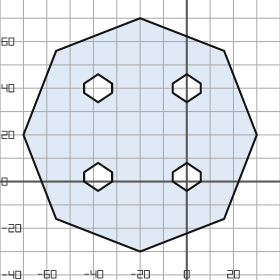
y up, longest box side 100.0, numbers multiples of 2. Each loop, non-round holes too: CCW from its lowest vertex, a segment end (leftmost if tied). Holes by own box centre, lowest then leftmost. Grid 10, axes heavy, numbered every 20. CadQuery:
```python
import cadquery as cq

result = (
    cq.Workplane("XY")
    .moveTo(-20.0, -30.0)
    .lineTo(16.0, -16.0)
    .lineTo(30.0, 20.0)
    .lineTo(16.0, 56.0)
    .lineTo(-20.0, 70.0)
    .lineTo(-56.0, 56.0)
    .lineTo(-70.0, 20.0)
    .lineTo(-56.0, -16.0)
    .close()
    .moveTo(-38.0, -4.0)
    .lineTo(-32.0, 0.0)
    .lineTo(-32.0, 4.0)
    .lineTo(-38.0, 8.0)
    .lineTo(-44.0, 4.0)
    .lineTo(-44.0, 0.0)
    .close()
    .moveTo(0.0, -4.0)
    .lineTo(6.0, 0.0)
    .lineTo(6.0, 4.0)
    .lineTo(0.0, 8.0)
    .lineTo(-6.0, 4.0)
    .lineTo(-6.0, 0.0)
    .close()
    .moveTo(-38.0, 34.0)
    .lineTo(-32.0, 38.0)
    .lineTo(-32.0, 42.0)
    .lineTo(-38.0, 46.0)
    .lineTo(-44.0, 42.0)
    .lineTo(-44.0, 38.0)
    .close()
    .moveTo(0.0, 34.0)
    .lineTo(6.0, 38.0)
    .lineTo(6.0, 42.0)
    .lineTo(0.0, 46.0)
    .lineTo(-6.0, 42.0)
    .lineTo(-6.0, 38.0)
    .close()
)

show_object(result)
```